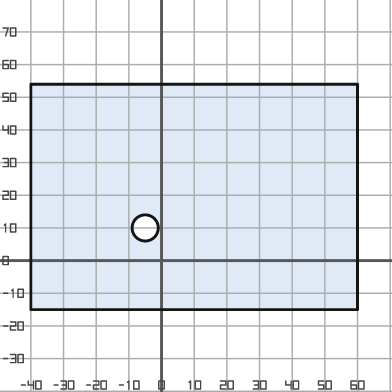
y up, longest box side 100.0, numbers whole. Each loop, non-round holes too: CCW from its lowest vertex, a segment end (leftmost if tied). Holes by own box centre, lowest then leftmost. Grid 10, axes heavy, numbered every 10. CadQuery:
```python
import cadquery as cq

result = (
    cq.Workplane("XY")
    .moveTo(-40.0, -15.0)
    .lineTo(60.0, -15.0)
    .lineTo(60.0, 54.0)
    .lineTo(-40.0, 54.0)
    .close()
    .moveTo(-5.0, 10.0)
    .circle(4.0)
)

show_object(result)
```